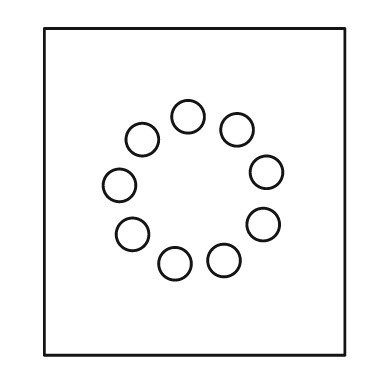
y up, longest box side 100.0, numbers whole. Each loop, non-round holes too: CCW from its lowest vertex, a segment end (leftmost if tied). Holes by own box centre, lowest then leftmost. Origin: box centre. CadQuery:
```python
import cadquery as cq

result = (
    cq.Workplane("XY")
    .moveTo(-46.0, -50.0)
    .lineTo(46.0, -50.0)
    .lineTo(46.0, 50.0)
    .lineTo(-46.0, 50.0)
    .close()
    .moveTo(-6.0, -22.0)
    .circle(5.0)
    .moveTo(9.0, -21.0)
    .circle(5.0)
    .moveTo(-19.0, -13.0)
    .circle(5.0)
    .moveTo(21.0, -10.0)
    .circle(5.0)
    .moveTo(-23.0, 2.0)
    .circle(5.0)
    .moveTo(22.0, 6.0)
    .circle(5.0)
    .moveTo(-16.0, 16.0)
    .circle(5.0)
    .moveTo(13.0, 19.0)
    .circle(5.0)
    .moveTo(-2.0, 23.0)
    .circle(5.0)
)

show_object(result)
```